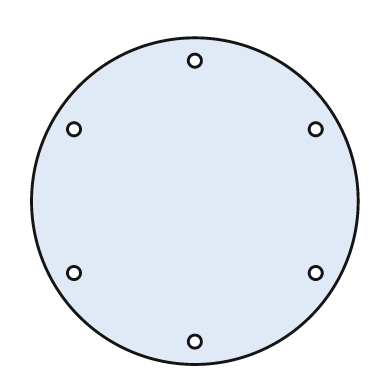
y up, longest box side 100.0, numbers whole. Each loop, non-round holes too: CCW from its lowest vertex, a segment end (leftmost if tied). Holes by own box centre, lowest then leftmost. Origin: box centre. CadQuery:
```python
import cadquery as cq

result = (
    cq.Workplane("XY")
    .moveTo(0.0, 0.0)
    .circle(50.0)
    .moveTo(0.0, -43.0)
    .circle(2.0)
    .moveTo(-37.0, -22.0)
    .circle(2.0)
    .moveTo(37.0, -22.0)
    .circle(2.0)
    .moveTo(-37.0, 22.0)
    .circle(2.0)
    .moveTo(37.0, 22.0)
    .circle(2.0)
    .moveTo(0.0, 43.0)
    .circle(2.0)
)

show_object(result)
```